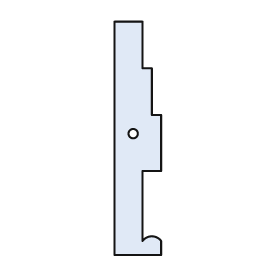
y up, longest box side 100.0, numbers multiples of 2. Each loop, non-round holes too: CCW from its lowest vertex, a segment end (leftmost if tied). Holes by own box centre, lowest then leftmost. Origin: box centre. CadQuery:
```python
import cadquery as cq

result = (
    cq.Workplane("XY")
    .moveTo(-10.0, -50.0)
    .lineTo(10.0, -50.0)
    .lineTo(10.0, -44.0)
    .threePointArc((6.0, -42.0), (2.0, -44.0))
    .lineTo(2.0, -14.0)
    .lineTo(10.0, -14.0)
    .lineTo(10.0, 10.0)
    .lineTo(6.0, 10.0)
    .lineTo(6.0, 30.0)
    .lineTo(2.0, 30.0)
    .lineTo(2.0, 50.0)
    .lineTo(-10.0, 50.0)
    .close()
    .moveTo(-2.0, 2.0)
    .circle(2.0)
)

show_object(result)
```